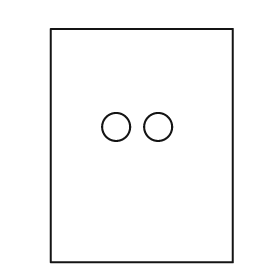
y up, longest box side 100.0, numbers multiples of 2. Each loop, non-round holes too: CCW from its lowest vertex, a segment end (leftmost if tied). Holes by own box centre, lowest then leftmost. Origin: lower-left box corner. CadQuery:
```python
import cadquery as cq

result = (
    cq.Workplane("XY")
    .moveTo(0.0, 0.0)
    .lineTo(78.0, 0.0)
    .lineTo(78.0, 100.0)
    .lineTo(0.0, 100.0)
    .close()
    .moveTo(28.0, 58.0)
    .circle(6.0)
    .moveTo(46.0, 58.0)
    .circle(6.0)
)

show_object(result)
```